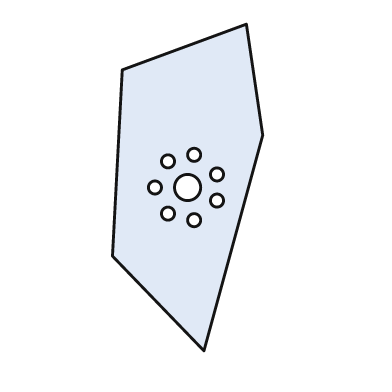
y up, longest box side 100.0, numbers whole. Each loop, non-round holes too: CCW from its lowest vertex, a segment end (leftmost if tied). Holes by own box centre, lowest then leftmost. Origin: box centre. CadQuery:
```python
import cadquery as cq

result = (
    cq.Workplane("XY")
    .moveTo(5.0, -50.0)
    .lineTo(23.0, 16.0)
    .lineTo(18.0, 50.0)
    .lineTo(-20.0, 36.0)
    .lineTo(-23.0, -21.0)
    .close()
    .moveTo(2.0, -10.0)
    .circle(2.0)
    .moveTo(-6.0, -8.0)
    .circle(2.0)
    .moveTo(9.0, -4.0)
    .circle(2.0)
    .moveTo(-10.0, 0.0)
    .circle(2.0)
    .moveTo(0.0, 0.0)
    .circle(4.0)
    .moveTo(9.0, 4.0)
    .circle(2.0)
    .moveTo(-6.0, 8.0)
    .circle(2.0)
    .moveTo(2.0, 10.0)
    .circle(2.0)
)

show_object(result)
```